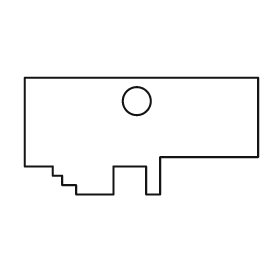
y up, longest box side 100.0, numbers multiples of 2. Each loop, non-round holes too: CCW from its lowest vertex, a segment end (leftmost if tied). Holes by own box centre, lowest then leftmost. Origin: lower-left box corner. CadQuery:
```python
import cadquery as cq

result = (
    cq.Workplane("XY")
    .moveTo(22.0, 0.0)
    .lineTo(38.0, 0.0)
    .lineTo(38.0, 12.0)
    .lineTo(52.0, 12.0)
    .lineTo(52.0, 0.0)
    .lineTo(58.0, 0.0)
    .lineTo(58.0, 16.0)
    .lineTo(100.0, 16.0)
    .lineTo(100.0, 50.0)
    .lineTo(0.0, 50.0)
    .lineTo(0.0, 12.0)
    .lineTo(12.0, 12.0)
    .lineTo(12.0, 8.0)
    .lineTo(16.0, 8.0)
    .lineTo(16.0, 4.0)
    .lineTo(22.0, 4.0)
    .close()
    .moveTo(48.0, 40.0)
    .circle(6.0)
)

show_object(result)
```